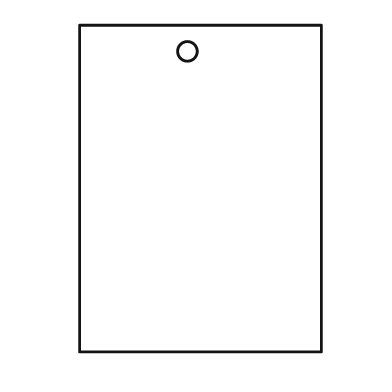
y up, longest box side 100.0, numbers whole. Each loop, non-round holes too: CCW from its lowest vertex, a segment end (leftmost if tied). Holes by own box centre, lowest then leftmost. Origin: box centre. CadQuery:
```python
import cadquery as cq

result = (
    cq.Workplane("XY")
    .moveTo(-37.0, -50.0)
    .lineTo(37.0, -50.0)
    .lineTo(37.0, 50.0)
    .lineTo(-37.0, 50.0)
    .close()
    .moveTo(-4.0, 42.0)
    .circle(3.0)
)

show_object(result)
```